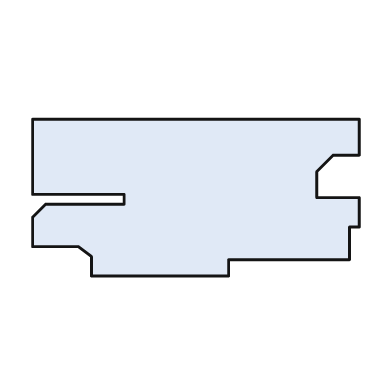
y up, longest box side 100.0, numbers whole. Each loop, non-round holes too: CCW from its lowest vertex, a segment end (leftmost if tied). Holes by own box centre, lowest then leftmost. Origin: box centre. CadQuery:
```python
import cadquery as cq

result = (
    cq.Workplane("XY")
    .moveTo(-32.0, -24.0)
    .lineTo(10.0, -24.0)
    .lineTo(10.0, -19.0)
    .lineTo(47.0, -19.0)
    .lineTo(47.0, -9.0)
    .lineTo(50.0, -9.0)
    .lineTo(50.0, 0.0)
    .lineTo(37.0, 0.0)
    .lineTo(37.0, 8.0)
    .lineTo(42.0, 13.0)
    .lineTo(50.0, 13.0)
    .lineTo(50.0, 24.0)
    .lineTo(-50.0, 24.0)
    .lineTo(-50.0, 1.0)
    .lineTo(-22.0, 1.0)
    .lineTo(-22.0, -2.0)
    .lineTo(-46.0, -2.0)
    .lineTo(-50.0, -6.0)
    .lineTo(-50.0, -15.0)
    .lineTo(-36.0, -15.0)
    .lineTo(-32.0, -18.0)
    .close()
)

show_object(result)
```